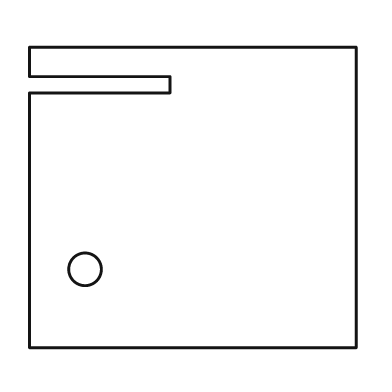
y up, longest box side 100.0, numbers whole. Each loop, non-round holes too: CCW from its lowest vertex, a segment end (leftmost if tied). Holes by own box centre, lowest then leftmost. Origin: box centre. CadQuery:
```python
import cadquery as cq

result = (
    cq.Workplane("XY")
    .moveTo(-50.0, -46.0)
    .lineTo(50.0, -46.0)
    .lineTo(50.0, 46.0)
    .lineTo(-50.0, 46.0)
    .lineTo(-50.0, 37.0)
    .lineTo(-7.0, 37.0)
    .lineTo(-7.0, 32.0)
    .lineTo(-50.0, 32.0)
    .close()
    .moveTo(-33.0, -22.0)
    .circle(5.0)
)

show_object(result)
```